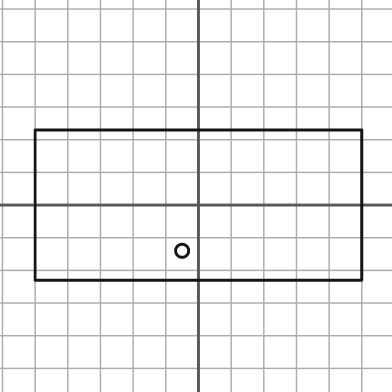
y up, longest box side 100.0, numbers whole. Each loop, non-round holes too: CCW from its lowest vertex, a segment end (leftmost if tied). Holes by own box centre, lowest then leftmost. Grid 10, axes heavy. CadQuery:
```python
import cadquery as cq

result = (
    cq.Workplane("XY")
    .moveTo(-50.0, -23.0)
    .lineTo(50.0, -23.0)
    .lineTo(50.0, 23.0)
    .lineTo(-50.0, 23.0)
    .close()
    .moveTo(-5.0, -14.0)
    .circle(2.0)
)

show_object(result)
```